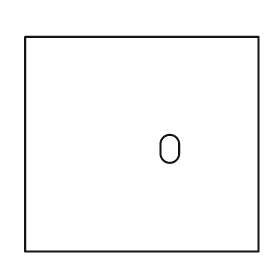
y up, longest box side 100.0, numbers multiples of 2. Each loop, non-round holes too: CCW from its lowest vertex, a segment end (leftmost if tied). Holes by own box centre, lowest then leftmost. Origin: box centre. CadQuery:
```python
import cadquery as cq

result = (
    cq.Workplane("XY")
    .moveTo(-50.0, -46.0)
    .lineTo(50.0, -46.0)
    .lineTo(50.0, 46.0)
    .lineTo(-50.0, 46.0)
    .close()
    .moveTo(8.0, -4.0)
    .threePointArc((12.0, -8.0), (16.0, -4.0))
    .lineTo(16.0, 0.0)
    .threePointArc((12.0, 4.0), (8.0, 0.0))
    .close()
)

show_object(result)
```